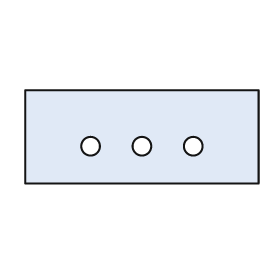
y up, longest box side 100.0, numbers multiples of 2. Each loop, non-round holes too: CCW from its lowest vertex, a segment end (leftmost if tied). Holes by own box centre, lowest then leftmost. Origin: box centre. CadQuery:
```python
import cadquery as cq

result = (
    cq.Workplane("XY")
    .moveTo(-50.0, -20.0)
    .lineTo(50.0, -20.0)
    .lineTo(50.0, 20.0)
    .lineTo(-50.0, 20.0)
    .close()
    .moveTo(-22.0, -4.0)
    .circle(4.0)
    .moveTo(0.0, -4.0)
    .circle(4.0)
    .moveTo(22.0, -4.0)
    .circle(4.0)
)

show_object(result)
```